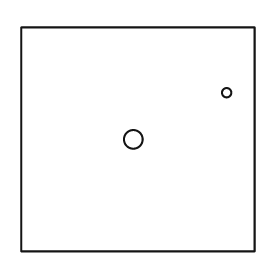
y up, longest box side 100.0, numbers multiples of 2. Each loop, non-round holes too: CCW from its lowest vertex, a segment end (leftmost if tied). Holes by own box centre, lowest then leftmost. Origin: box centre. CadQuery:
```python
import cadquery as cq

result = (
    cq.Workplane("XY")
    .moveTo(-50.0, -48.0)
    .lineTo(50.0, -48.0)
    .lineTo(50.0, 48.0)
    .lineTo(-50.0, 48.0)
    .close()
    .moveTo(-2.0, 0.0)
    .circle(4.0)
    .moveTo(38.0, 20.0)
    .circle(2.0)
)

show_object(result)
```